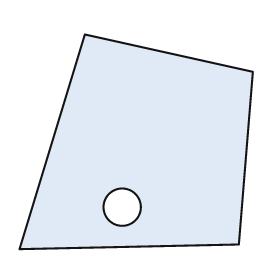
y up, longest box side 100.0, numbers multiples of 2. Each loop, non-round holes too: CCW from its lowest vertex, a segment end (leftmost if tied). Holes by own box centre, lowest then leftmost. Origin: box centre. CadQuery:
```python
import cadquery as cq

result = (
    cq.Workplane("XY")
    .moveTo(-50.0, -46.0)
    .lineTo(44.0, -44.0)
    .lineTo(50.0, 30.0)
    .lineTo(-22.0, 46.0)
    .close()
    .moveTo(-6.0, -28.0)
    .circle(8.0)
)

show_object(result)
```